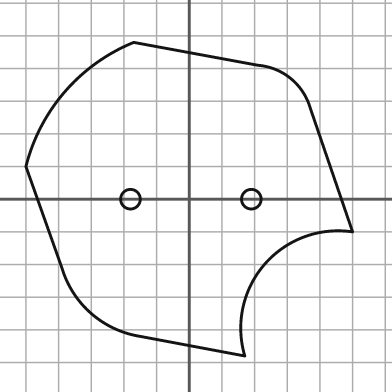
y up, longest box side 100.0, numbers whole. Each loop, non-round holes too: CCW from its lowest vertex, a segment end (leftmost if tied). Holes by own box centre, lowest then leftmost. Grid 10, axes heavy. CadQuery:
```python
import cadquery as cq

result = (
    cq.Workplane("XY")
    .moveTo(17.0, -48.0)
    .threePointArc((23.0, -20.0), (50.0, -10.0))
    .lineTo(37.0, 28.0)
    .threePointArc((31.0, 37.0), (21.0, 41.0))
    .lineTo(-17.0, 48.0)
    .threePointArc((-38.0, 33.0), (-50.0, 10.0))
    .lineTo(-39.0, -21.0)
    .threePointArc((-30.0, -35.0), (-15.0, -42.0))
    .close()
    .moveTo(-18.0, 0.0)
    .circle(3.0)
    .moveTo(19.0, 0.0)
    .circle(3.0)
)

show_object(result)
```